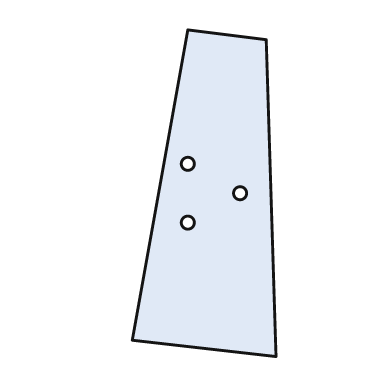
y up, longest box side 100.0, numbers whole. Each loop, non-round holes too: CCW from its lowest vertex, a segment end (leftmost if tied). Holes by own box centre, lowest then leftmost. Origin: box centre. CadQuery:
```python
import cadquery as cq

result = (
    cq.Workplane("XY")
    .moveTo(22.0, -50.0)
    .lineTo(19.0, 47.0)
    .lineTo(-5.0, 50.0)
    .lineTo(-22.0, -45.0)
    .close()
    .moveTo(-5.0, -9.0)
    .circle(2.0)
    .moveTo(11.0, 0.0)
    .circle(2.0)
    .moveTo(-5.0, 9.0)
    .circle(2.0)
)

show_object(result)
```